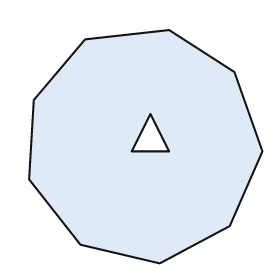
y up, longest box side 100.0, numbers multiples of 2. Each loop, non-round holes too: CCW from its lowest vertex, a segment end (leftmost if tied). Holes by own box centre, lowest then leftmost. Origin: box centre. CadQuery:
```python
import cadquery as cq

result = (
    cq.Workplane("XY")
    .moveTo(6.0, -50.0)
    .lineTo(36.0, -34.0)
    .lineTo(50.0, -2.0)
    .lineTo(38.0, 32.0)
    .lineTo(10.0, 50.0)
    .lineTo(-26.0, 46.0)
    .lineTo(-48.0, 20.0)
    .lineTo(-50.0, -14.0)
    .lineTo(-28.0, -42.0)
    .close()
    .moveTo(-6.0, -2.0)
    .lineTo(10.0, -2.0)
    .lineTo(2.0, 14.0)
    .close()
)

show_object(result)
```